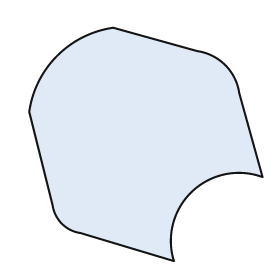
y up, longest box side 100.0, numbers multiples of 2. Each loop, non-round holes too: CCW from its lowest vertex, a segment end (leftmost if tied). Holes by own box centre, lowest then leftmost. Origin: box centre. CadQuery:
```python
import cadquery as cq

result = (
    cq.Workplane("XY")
    .moveTo(12.0, -50.0)
    .threePointArc((20.0, -20.0), (50.0, -14.0))
    .lineTo(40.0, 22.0)
    .threePointArc((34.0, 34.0), (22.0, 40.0))
    .lineTo(-14.0, 50.0)
    .threePointArc((-38.0, 38.0), (-50.0, 14.0))
    .lineTo(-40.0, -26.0)
    .threePointArc((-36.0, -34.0), (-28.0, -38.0))
    .close()
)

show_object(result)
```